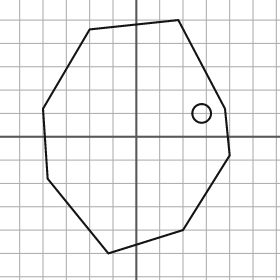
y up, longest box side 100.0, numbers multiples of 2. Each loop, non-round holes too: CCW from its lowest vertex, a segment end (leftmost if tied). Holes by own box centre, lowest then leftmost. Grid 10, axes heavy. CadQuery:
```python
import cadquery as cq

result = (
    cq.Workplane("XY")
    .moveTo(-12.0, -50.0)
    .lineTo(20.0, -40.0)
    .lineTo(40.0, -8.0)
    .lineTo(38.0, 12.0)
    .lineTo(18.0, 50.0)
    .lineTo(-20.0, 46.0)
    .lineTo(-40.0, 12.0)
    .lineTo(-38.0, -18.0)
    .close()
    .moveTo(28.0, 10.0)
    .circle(4.0)
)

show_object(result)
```